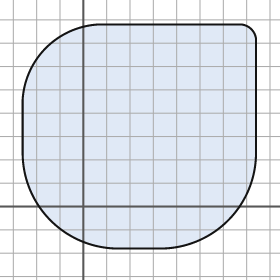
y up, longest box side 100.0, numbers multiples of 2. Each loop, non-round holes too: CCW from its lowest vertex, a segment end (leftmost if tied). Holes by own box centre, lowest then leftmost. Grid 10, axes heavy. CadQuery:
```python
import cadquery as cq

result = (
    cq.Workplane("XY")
    .moveTo(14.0, -18.0)
    .lineTo(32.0, -18.0)
    .threePointArc((62.0, -6.0), (74.0, 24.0))
    .lineTo(74.0, 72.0)
    .threePointArc((72.0, 76.0), (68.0, 78.0))
    .lineTo(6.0, 78.0)
    .threePointArc((-16.0, 68.0), (-26.0, 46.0))
    .lineTo(-26.0, 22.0)
    .threePointArc((-14.0, -6.0), (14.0, -18.0))
    .close()
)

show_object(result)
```